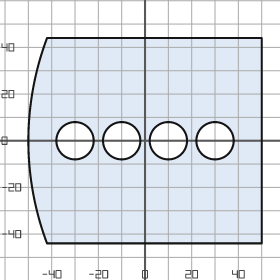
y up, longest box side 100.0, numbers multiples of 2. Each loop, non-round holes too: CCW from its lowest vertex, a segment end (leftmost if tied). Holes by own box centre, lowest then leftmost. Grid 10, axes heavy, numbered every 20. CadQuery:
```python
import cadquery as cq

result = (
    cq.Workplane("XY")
    .moveTo(-42.0, -44.0)
    .lineTo(50.0, -44.0)
    .lineTo(50.0, 44.0)
    .lineTo(-42.0, 44.0)
    .threePointArc((-50.0, 0.0), (-42.0, -44.0))
    .close()
    .moveTo(-30.0, 0.0)
    .circle(8.0)
    .moveTo(-10.0, 0.0)
    .circle(8.0)
    .moveTo(10.0, 0.0)
    .circle(8.0)
    .moveTo(30.0, 0.0)
    .circle(8.0)
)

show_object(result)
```